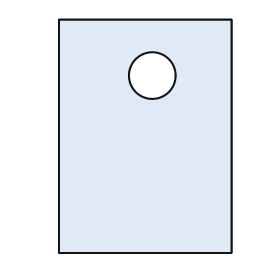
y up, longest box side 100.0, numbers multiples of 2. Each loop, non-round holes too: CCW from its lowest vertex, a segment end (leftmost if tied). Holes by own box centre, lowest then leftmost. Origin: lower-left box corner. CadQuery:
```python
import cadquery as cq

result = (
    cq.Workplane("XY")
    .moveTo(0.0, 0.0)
    .lineTo(74.0, 0.0)
    .lineTo(74.0, 100.0)
    .lineTo(0.0, 100.0)
    .close()
    .moveTo(40.0, 76.0)
    .circle(10.0)
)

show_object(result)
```